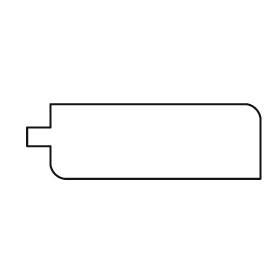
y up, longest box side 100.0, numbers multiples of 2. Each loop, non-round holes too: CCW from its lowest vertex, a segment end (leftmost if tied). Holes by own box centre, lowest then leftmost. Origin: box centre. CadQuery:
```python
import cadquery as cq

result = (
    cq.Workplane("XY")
    .moveTo(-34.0, -16.0)
    .lineTo(50.0, -16.0)
    .lineTo(50.0, 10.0)
    .threePointArc((48.0, 14.0), (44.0, 16.0))
    .lineTo(-40.0, 16.0)
    .lineTo(-40.0, 6.0)
    .lineTo(-50.0, 6.0)
    .lineTo(-50.0, -2.0)
    .lineTo(-40.0, -2.0)
    .lineTo(-40.0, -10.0)
    .threePointArc((-38.0, -14.0), (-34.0, -16.0))
    .close()
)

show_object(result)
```